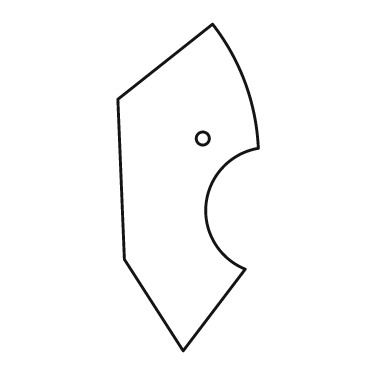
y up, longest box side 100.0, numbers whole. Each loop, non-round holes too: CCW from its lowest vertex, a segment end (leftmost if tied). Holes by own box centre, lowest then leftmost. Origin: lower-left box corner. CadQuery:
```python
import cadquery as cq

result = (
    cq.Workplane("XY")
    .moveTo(20.0, 0.0)
    .lineTo(39.0, 25.0)
    .threePointArc((27.0, 45.0), (43.0, 62.0))
    .threePointArc((39.0, 82.0), (29.0, 100.0))
    .lineTo(0.0, 77.0)
    .lineTo(2.0, 28.0)
    .close()
    .moveTo(26.0, 65.0)
    .circle(2.0)
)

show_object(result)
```